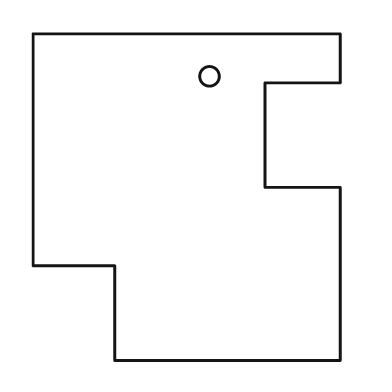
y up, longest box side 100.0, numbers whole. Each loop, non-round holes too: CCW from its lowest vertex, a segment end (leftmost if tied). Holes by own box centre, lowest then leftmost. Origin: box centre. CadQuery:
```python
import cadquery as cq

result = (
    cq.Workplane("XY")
    .moveTo(-22.0, -50.0)
    .lineTo(47.0, -50.0)
    .lineTo(47.0, 3.0)
    .lineTo(24.0, 3.0)
    .lineTo(24.0, 35.0)
    .lineTo(47.0, 35.0)
    .lineTo(47.0, 50.0)
    .lineTo(-47.0, 50.0)
    .lineTo(-47.0, -21.0)
    .lineTo(-22.0, -21.0)
    .close()
    .moveTo(7.0, 37.0)
    .circle(3.0)
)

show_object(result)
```